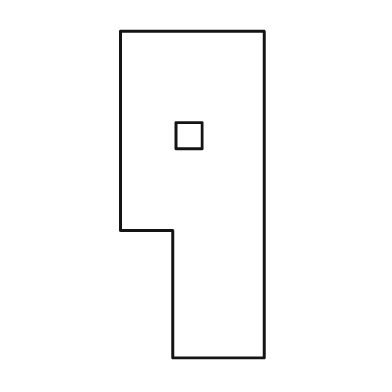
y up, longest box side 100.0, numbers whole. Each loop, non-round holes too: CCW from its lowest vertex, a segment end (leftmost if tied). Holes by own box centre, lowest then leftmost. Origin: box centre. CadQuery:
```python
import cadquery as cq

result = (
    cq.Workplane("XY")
    .moveTo(-6.0, -50.0)
    .lineTo(22.0, -50.0)
    .lineTo(22.0, 50.0)
    .lineTo(-22.0, 50.0)
    .lineTo(-22.0, -11.0)
    .lineTo(-6.0, -11.0)
    .close()
    .moveTo(-5.0, 14.0)
    .lineTo(3.0, 14.0)
    .lineTo(3.0, 22.0)
    .lineTo(-5.0, 22.0)
    .close()
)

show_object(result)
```